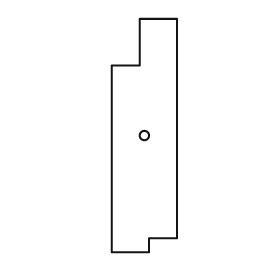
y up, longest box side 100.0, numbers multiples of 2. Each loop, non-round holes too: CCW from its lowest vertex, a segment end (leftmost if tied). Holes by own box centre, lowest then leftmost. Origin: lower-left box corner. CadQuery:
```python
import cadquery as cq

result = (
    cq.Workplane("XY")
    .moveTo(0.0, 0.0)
    .lineTo(16.0, 0.0)
    .lineTo(16.0, 6.0)
    .lineTo(28.0, 6.0)
    .lineTo(28.0, 100.0)
    .lineTo(12.0, 100.0)
    .lineTo(12.0, 80.0)
    .lineTo(0.0, 80.0)
    .close()
    .moveTo(14.0, 50.0)
    .circle(2.0)
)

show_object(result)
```